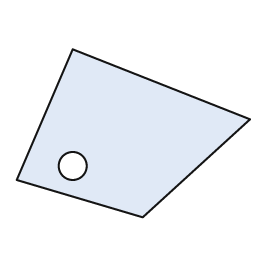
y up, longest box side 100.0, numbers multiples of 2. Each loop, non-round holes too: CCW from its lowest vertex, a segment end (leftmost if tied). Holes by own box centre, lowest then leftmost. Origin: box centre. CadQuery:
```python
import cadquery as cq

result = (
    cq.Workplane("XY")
    .moveTo(4.0, -36.0)
    .lineTo(50.0, 6.0)
    .lineTo(-26.0, 36.0)
    .lineTo(-50.0, -20.0)
    .close()
    .moveTo(-26.0, -14.0)
    .circle(6.0)
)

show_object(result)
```